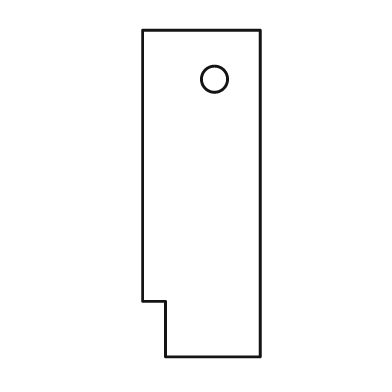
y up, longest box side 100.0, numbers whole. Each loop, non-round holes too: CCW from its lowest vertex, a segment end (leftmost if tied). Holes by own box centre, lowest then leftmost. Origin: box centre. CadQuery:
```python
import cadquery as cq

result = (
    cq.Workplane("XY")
    .moveTo(-11.0, -50.0)
    .lineTo(18.0, -50.0)
    .lineTo(18.0, 50.0)
    .lineTo(-18.0, 50.0)
    .lineTo(-18.0, -33.0)
    .lineTo(-11.0, -33.0)
    .close()
    .moveTo(4.0, 35.0)
    .circle(4.0)
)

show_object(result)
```